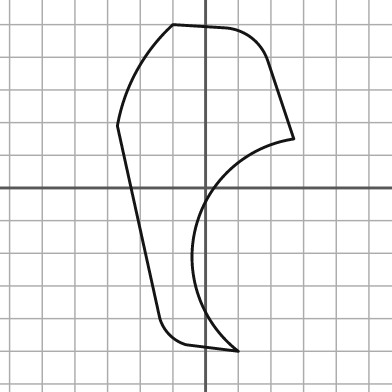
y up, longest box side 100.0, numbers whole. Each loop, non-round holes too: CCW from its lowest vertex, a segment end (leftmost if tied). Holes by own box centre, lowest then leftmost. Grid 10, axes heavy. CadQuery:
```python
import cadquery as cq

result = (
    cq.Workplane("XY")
    .moveTo(10.0, -50.0)
    .threePointArc((-3.0, -12.0), (27.0, 15.0))
    .lineTo(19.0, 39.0)
    .threePointArc((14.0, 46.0), (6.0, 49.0))
    .lineTo(-10.0, 50.0)
    .threePointArc((-21.0, 36.0), (-27.0, 19.0))
    .lineTo(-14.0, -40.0)
    .threePointArc((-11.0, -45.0), (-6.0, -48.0))
    .close()
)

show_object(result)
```